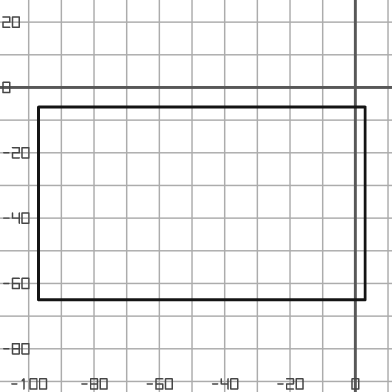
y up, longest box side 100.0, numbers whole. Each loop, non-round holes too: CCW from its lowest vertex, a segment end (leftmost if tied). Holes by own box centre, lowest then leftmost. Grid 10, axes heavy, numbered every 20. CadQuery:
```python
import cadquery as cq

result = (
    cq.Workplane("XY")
    .moveTo(-97.0, -65.0)
    .lineTo(3.0, -65.0)
    .lineTo(3.0, -6.0)
    .lineTo(-97.0, -6.0)
    .close()
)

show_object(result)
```